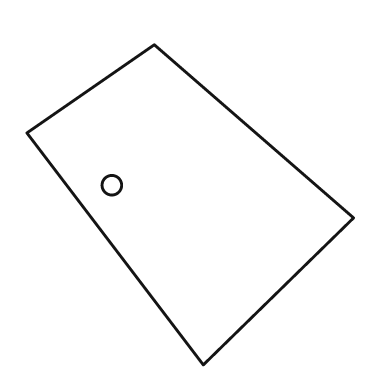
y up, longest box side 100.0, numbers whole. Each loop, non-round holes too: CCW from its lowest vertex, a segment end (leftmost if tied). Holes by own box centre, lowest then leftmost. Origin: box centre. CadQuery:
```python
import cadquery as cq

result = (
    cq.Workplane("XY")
    .moveTo(4.0, -49.0)
    .lineTo(50.0, -4.0)
    .lineTo(-11.0, 49.0)
    .lineTo(-50.0, 22.0)
    .close()
    .moveTo(-24.0, 6.0)
    .circle(3.0)
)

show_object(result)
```